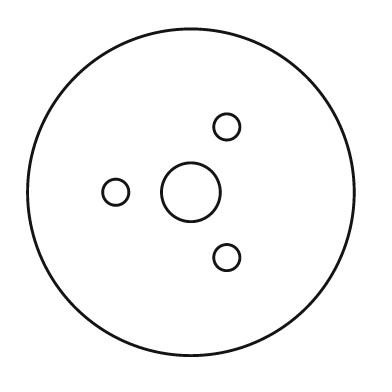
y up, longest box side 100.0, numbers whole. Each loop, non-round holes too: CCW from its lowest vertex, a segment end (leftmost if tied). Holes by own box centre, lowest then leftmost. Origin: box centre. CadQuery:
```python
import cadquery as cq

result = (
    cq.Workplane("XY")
    .moveTo(0.0, 0.0)
    .circle(50.0)
    .moveTo(11.0, -20.0)
    .circle(4.0)
    .moveTo(-23.0, 0.0)
    .circle(4.0)
    .moveTo(0.0, 0.0)
    .circle(9.0)
    .moveTo(11.0, 20.0)
    .circle(4.0)
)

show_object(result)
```